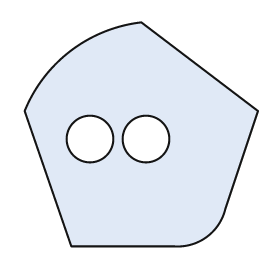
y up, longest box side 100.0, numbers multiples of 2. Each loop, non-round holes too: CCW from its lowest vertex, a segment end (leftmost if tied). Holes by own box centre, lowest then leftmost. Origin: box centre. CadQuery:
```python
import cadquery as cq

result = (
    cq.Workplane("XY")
    .moveTo(-30.0, -48.0)
    .lineTo(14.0, -48.0)
    .threePointArc((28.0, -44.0), (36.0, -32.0))
    .lineTo(50.0, 10.0)
    .lineTo(0.0, 48.0)
    .threePointArc((-30.0, 36.0), (-50.0, 10.0))
    .close()
    .moveTo(-22.0, -2.0)
    .circle(10.0)
    .moveTo(2.0, -2.0)
    .circle(10.0)
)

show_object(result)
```